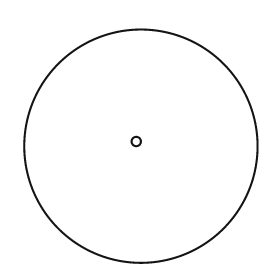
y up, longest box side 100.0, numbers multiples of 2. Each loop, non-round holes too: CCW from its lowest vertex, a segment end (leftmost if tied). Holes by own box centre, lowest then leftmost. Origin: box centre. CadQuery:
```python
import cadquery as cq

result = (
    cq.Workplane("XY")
    .moveTo(0.0, 0.0)
    .circle(50.0)
    .moveTo(-2.0, 2.0)
    .circle(2.0)
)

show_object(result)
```